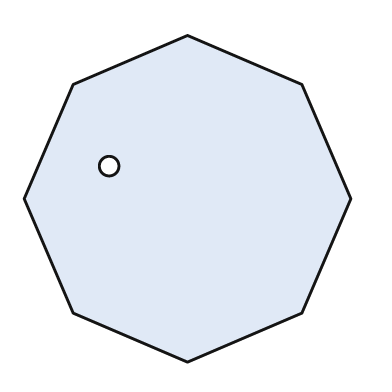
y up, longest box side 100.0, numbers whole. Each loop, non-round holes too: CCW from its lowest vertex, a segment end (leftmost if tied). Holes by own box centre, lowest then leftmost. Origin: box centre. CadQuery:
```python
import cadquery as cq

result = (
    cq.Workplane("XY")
    .moveTo(0.0, -50.0)
    .lineTo(35.0, -35.0)
    .lineTo(50.0, 0.0)
    .lineTo(35.0, 35.0)
    .lineTo(0.0, 50.0)
    .lineTo(-35.0, 35.0)
    .lineTo(-50.0, 0.0)
    .lineTo(-35.0, -35.0)
    .close()
    .moveTo(-24.0, 10.0)
    .circle(3.0)
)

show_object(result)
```